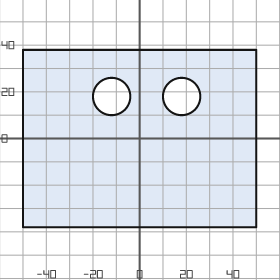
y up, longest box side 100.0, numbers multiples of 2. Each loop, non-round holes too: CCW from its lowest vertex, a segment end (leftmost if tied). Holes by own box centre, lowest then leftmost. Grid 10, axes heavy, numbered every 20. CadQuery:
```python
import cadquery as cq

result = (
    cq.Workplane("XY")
    .moveTo(-50.0, -38.0)
    .lineTo(50.0, -38.0)
    .lineTo(50.0, 38.0)
    .lineTo(-50.0, 38.0)
    .close()
    .moveTo(-12.0, 18.0)
    .circle(8.0)
    .moveTo(18.0, 18.0)
    .circle(8.0)
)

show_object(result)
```